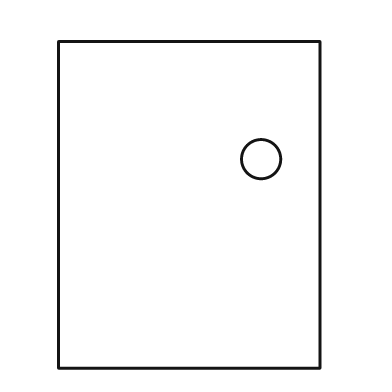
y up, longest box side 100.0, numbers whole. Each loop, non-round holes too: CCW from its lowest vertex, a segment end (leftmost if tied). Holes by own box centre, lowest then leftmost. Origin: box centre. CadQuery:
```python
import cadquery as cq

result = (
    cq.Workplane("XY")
    .moveTo(-40.0, -50.0)
    .lineTo(40.0, -50.0)
    .lineTo(40.0, 50.0)
    .lineTo(-40.0, 50.0)
    .close()
    .moveTo(22.0, 14.0)
    .circle(6.0)
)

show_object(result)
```